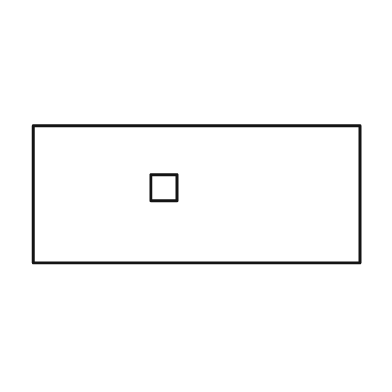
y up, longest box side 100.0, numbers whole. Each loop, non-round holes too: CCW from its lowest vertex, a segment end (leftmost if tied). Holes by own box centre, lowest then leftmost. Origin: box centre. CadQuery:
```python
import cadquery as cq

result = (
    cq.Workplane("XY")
    .moveTo(-50.0, -21.0)
    .lineTo(50.0, -21.0)
    .lineTo(50.0, 21.0)
    .lineTo(-50.0, 21.0)
    .close()
    .moveTo(-14.0, -2.0)
    .lineTo(-6.0, -2.0)
    .lineTo(-6.0, 6.0)
    .lineTo(-14.0, 6.0)
    .close()
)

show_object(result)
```